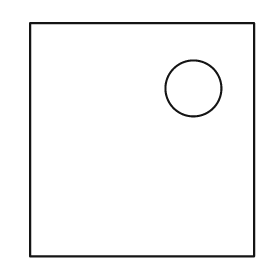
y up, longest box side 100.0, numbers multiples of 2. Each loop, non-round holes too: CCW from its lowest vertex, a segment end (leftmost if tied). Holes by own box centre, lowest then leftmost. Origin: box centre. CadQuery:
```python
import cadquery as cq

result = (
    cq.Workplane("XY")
    .moveTo(-48.0, -50.0)
    .lineTo(48.0, -50.0)
    .lineTo(48.0, 50.0)
    .lineTo(-48.0, 50.0)
    .close()
    .moveTo(22.0, 22.0)
    .circle(12.0)
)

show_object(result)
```